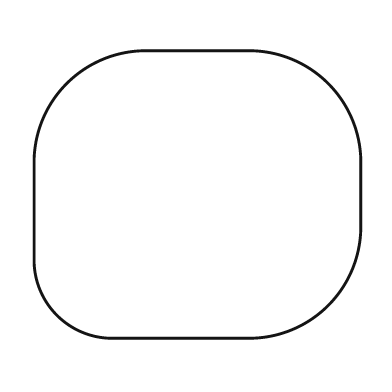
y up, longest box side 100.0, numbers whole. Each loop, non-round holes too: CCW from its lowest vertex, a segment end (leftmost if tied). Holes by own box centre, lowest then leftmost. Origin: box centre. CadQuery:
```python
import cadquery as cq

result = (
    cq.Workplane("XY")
    .moveTo(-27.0, -44.0)
    .lineTo(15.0, -44.0)
    .threePointArc((40.0, -34.0), (50.0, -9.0))
    .lineTo(50.0, 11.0)
    .threePointArc((40.0, 34.0), (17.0, 44.0))
    .lineTo(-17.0, 44.0)
    .threePointArc((-40.0, 34.0), (-50.0, 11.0))
    .lineTo(-50.0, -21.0)
    .threePointArc((-43.0, -37.0), (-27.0, -44.0))
    .close()
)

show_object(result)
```